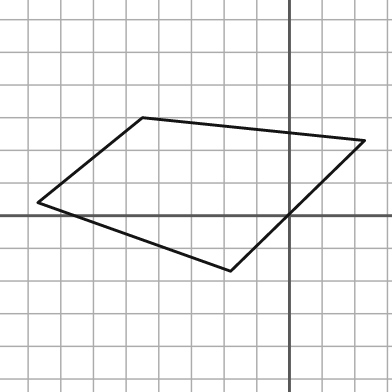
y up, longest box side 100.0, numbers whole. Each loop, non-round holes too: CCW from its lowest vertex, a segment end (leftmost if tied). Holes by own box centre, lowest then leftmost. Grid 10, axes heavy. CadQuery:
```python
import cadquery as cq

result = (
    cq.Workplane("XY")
    .moveTo(-18.0, -17.0)
    .lineTo(23.0, 23.0)
    .lineTo(-45.0, 30.0)
    .lineTo(-77.0, 4.0)
    .close()
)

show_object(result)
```